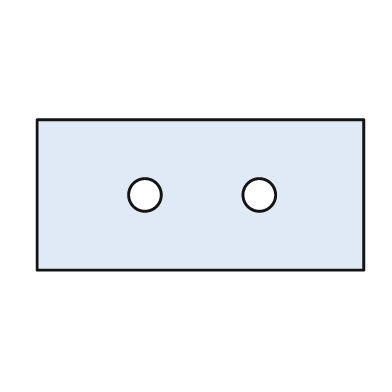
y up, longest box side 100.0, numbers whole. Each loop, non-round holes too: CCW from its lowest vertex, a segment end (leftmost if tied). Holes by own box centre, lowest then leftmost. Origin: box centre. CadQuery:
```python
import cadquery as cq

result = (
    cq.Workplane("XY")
    .moveTo(-50.0, -23.0)
    .lineTo(50.0, -23.0)
    .lineTo(50.0, 23.0)
    .lineTo(-50.0, 23.0)
    .close()
    .moveTo(-17.0, 0.0)
    .circle(5.0)
    .moveTo(18.0, 0.0)
    .circle(5.0)
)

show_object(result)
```